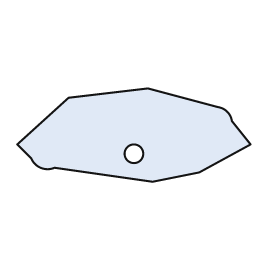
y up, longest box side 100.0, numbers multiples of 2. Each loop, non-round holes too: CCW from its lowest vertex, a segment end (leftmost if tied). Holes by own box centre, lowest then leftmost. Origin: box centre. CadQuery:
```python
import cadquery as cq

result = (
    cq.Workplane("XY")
    .moveTo(8.0, -20.0)
    .lineTo(28.0, -16.0)
    .lineTo(50.0, -4.0)
    .lineTo(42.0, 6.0)
    .threePointArc((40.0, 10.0), (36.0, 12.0))
    .lineTo(6.0, 20.0)
    .lineTo(-28.0, 16.0)
    .lineTo(-50.0, -4.0)
    .lineTo(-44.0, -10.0)
    .threePointArc((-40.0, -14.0), (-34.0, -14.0))
    .close()
    .moveTo(0.0, -8.0)
    .circle(4.0)
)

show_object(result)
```